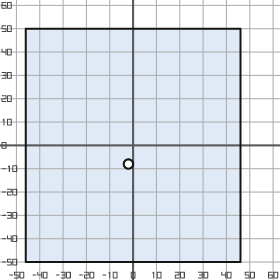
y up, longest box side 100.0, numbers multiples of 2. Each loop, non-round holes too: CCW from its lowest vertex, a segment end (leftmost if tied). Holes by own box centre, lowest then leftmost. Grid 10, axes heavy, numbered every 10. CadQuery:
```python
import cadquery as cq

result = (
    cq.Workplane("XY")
    .moveTo(-46.0, -50.0)
    .lineTo(46.0, -50.0)
    .lineTo(46.0, 50.0)
    .lineTo(-46.0, 50.0)
    .close()
    .moveTo(-2.0, -8.0)
    .circle(2.0)
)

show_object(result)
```